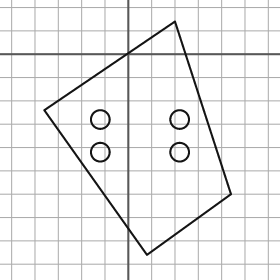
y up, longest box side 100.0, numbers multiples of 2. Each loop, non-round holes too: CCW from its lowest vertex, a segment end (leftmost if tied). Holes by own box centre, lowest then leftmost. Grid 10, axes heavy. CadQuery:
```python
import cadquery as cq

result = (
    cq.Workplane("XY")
    .moveTo(8.0, -86.0)
    .lineTo(44.0, -60.0)
    .lineTo(20.0, 14.0)
    .lineTo(-36.0, -24.0)
    .close()
    .moveTo(-12.0, -42.0)
    .circle(4.0)
    .moveTo(22.0, -42.0)
    .circle(4.0)
    .moveTo(-12.0, -28.0)
    .circle(4.0)
    .moveTo(22.0, -28.0)
    .circle(4.0)
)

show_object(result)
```